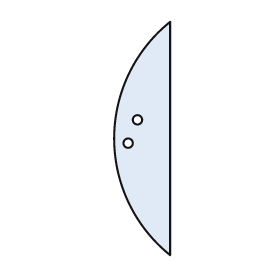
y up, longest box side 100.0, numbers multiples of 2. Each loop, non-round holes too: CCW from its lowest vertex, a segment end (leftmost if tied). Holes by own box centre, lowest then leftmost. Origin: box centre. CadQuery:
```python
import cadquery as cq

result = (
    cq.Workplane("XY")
    .moveTo(12.0, -50.0)
    .lineTo(12.0, 50.0)
    .threePointArc((-12.0, 0.0), (12.0, -50.0))
    .close()
    .moveTo(-6.0, -2.0)
    .circle(2.0)
    .moveTo(-2.0, 8.0)
    .circle(2.0)
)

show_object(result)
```